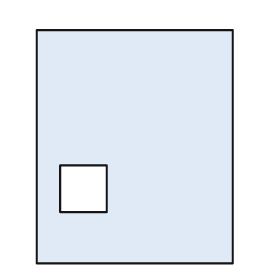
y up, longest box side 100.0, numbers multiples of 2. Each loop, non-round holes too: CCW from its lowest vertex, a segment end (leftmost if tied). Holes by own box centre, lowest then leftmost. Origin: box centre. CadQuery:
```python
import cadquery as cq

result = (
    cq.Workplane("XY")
    .moveTo(-42.0, -50.0)
    .lineTo(42.0, -50.0)
    .lineTo(42.0, 50.0)
    .lineTo(-42.0, 50.0)
    .close()
    .moveTo(-32.0, -28.0)
    .lineTo(-12.0, -28.0)
    .lineTo(-12.0, -8.0)
    .lineTo(-32.0, -8.0)
    .close()
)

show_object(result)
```